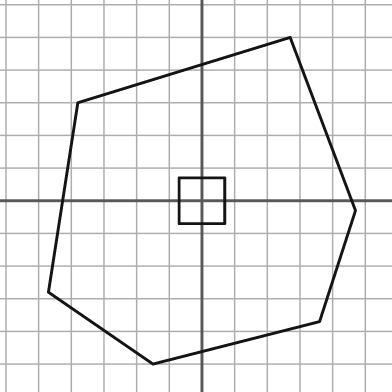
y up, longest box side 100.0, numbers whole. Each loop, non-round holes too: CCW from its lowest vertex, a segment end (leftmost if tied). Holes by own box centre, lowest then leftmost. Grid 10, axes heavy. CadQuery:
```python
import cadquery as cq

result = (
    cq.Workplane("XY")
    .moveTo(-15.0, -50.0)
    .lineTo(36.0, -37.0)
    .lineTo(47.0, -3.0)
    .lineTo(27.0, 50.0)
    .lineTo(-38.0, 30.0)
    .lineTo(-47.0, -28.0)
    .close()
    .moveTo(-7.0, -7.0)
    .lineTo(7.0, -7.0)
    .lineTo(7.0, 7.0)
    .lineTo(-7.0, 7.0)
    .close()
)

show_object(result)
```